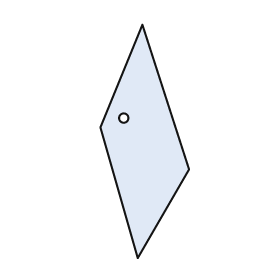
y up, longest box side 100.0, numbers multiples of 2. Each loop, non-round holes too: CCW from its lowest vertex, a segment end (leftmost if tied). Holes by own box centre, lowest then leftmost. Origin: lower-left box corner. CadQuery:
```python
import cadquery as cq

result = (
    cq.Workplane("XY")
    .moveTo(16.0, 0.0)
    .lineTo(38.0, 38.0)
    .lineTo(18.0, 100.0)
    .lineTo(0.0, 56.0)
    .close()
    .moveTo(10.0, 60.0)
    .circle(2.0)
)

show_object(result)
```